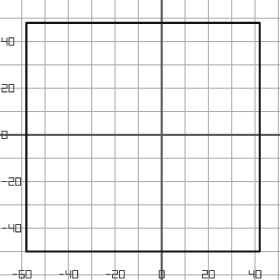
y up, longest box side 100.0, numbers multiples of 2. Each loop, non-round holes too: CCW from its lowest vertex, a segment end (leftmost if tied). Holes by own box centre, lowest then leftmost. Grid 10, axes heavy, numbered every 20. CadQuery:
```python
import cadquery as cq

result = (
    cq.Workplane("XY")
    .moveTo(-58.0, -50.0)
    .lineTo(42.0, -50.0)
    .lineTo(42.0, 48.0)
    .lineTo(-58.0, 48.0)
    .close()
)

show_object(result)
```